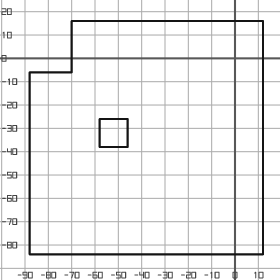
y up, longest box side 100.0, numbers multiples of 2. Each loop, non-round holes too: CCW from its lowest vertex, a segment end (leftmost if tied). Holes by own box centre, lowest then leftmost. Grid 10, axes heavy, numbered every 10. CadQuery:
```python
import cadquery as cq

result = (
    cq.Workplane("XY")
    .moveTo(-88.0, -84.0)
    .lineTo(12.0, -84.0)
    .lineTo(12.0, 16.0)
    .lineTo(-70.0, 16.0)
    .lineTo(-70.0, -6.0)
    .lineTo(-88.0, -6.0)
    .close()
    .moveTo(-58.0, -38.0)
    .lineTo(-46.0, -38.0)
    .lineTo(-46.0, -26.0)
    .lineTo(-58.0, -26.0)
    .close()
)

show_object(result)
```